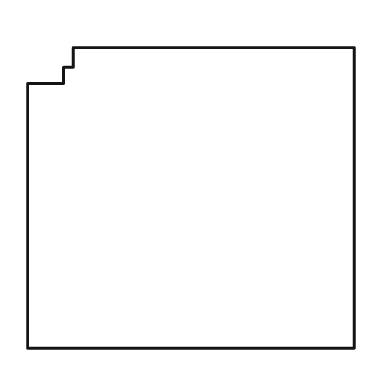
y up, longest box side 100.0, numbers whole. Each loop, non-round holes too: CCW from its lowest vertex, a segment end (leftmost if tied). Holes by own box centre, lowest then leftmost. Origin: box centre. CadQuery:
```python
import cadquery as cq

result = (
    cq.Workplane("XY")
    .moveTo(-50.0, -46.0)
    .lineTo(50.0, -46.0)
    .lineTo(50.0, 46.0)
    .lineTo(-36.0, 46.0)
    .lineTo(-36.0, 40.0)
    .lineTo(-39.0, 40.0)
    .lineTo(-39.0, 35.0)
    .lineTo(-50.0, 35.0)
    .close()
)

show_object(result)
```